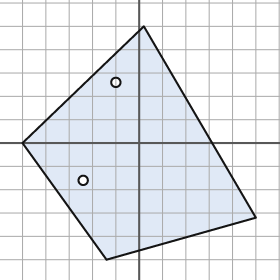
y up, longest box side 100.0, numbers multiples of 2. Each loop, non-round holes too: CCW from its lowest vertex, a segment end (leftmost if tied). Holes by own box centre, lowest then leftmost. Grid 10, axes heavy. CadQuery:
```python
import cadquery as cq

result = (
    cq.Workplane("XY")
    .moveTo(-14.0, -50.0)
    .lineTo(50.0, -32.0)
    .lineTo(2.0, 50.0)
    .lineTo(-50.0, 0.0)
    .close()
    .moveTo(-24.0, -16.0)
    .circle(2.0)
    .moveTo(-10.0, 26.0)
    .circle(2.0)
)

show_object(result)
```